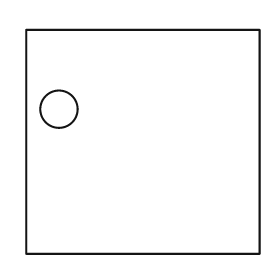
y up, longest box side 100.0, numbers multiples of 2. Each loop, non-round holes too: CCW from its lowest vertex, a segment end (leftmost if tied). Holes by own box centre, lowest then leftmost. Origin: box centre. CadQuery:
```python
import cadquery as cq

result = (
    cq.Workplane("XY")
    .moveTo(-50.0, -48.0)
    .lineTo(50.0, -48.0)
    .lineTo(50.0, 48.0)
    .lineTo(-50.0, 48.0)
    .close()
    .moveTo(-36.0, 14.0)
    .circle(8.0)
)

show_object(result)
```